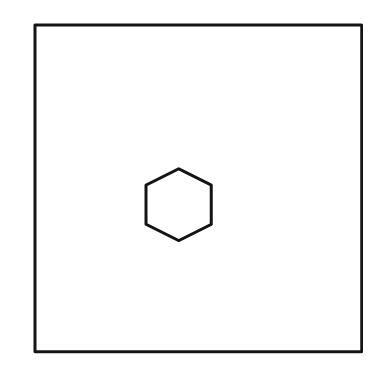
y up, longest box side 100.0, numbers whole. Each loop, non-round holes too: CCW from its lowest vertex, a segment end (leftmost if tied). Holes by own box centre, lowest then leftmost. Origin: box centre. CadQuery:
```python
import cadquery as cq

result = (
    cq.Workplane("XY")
    .moveTo(-50.0, -50.0)
    .lineTo(50.0, -50.0)
    .lineTo(50.0, 50.0)
    .lineTo(-50.0, 50.0)
    .close()
    .moveTo(-6.0, -16.0)
    .lineTo(4.0, -11.0)
    .lineTo(4.0, 1.0)
    .lineTo(-6.0, 6.0)
    .lineTo(-16.0, 1.0)
    .lineTo(-16.0, -11.0)
    .close()
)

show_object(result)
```